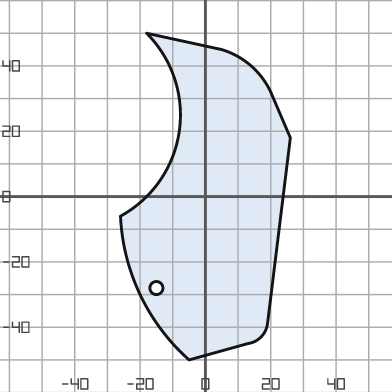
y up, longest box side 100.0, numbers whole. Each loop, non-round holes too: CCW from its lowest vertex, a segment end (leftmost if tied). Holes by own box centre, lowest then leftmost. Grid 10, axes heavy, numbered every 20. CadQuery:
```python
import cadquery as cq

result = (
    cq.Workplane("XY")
    .moveTo(-5.0, -50.0)
    .lineTo(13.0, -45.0)
    .threePointArc((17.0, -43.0), (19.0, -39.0))
    .lineTo(26.0, 18.0)
    .lineTo(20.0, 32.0)
    .threePointArc((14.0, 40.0), (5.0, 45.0))
    .lineTo(-18.0, 50.0)
    .threePointArc((-8.0, 20.0), (-26.0, -6.0))
    .threePointArc((-20.0, -30.0), (-5.0, -50.0))
    .close()
    .moveTo(-15.0, -28.0)
    .circle(2.0)
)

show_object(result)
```